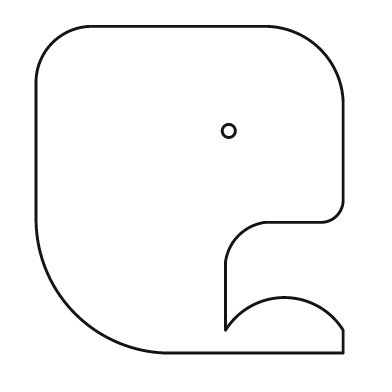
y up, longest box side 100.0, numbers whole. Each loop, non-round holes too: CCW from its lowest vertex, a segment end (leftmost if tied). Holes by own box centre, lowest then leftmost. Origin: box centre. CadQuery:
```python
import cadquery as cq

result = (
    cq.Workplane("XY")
    .moveTo(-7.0, -50.0)
    .lineTo(47.0, -50.0)
    .lineTo(47.0, -43.0)
    .threePointArc((29.0, -33.0), (11.0, -43.0))
    .lineTo(11.0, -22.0)
    .threePointArc((15.0, -14.0), (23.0, -10.0))
    .lineTo(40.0, -10.0)
    .threePointArc((45.0, -8.0), (47.0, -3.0))
    .lineTo(47.0, 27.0)
    .threePointArc((40.0, 43.0), (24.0, 50.0))
    .lineTo(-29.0, 50.0)
    .threePointArc((-42.0, 45.0), (-47.0, 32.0))
    .lineTo(-47.0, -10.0)
    .threePointArc((-35.0, -38.0), (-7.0, -50.0))
    .close()
    .moveTo(12.0, 18.0)
    .circle(2.0)
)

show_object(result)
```